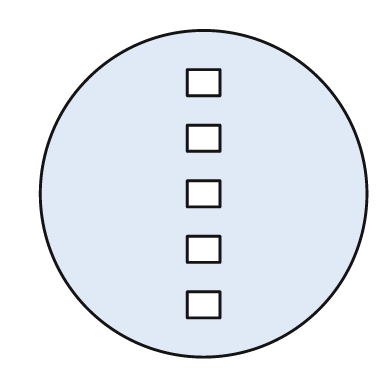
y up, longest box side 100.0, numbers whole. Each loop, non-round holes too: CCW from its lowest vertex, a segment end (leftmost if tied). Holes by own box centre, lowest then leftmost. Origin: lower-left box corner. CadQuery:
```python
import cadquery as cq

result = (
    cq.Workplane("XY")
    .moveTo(50.0, 50.0)
    .circle(50.0)
    .moveTo(45.0, 12.0)
    .lineTo(55.0, 12.0)
    .lineTo(55.0, 20.0)
    .lineTo(45.0, 20.0)
    .close()
    .moveTo(45.0, 29.0)
    .lineTo(55.0, 29.0)
    .lineTo(55.0, 37.0)
    .lineTo(45.0, 37.0)
    .close()
    .moveTo(45.0, 46.0)
    .lineTo(55.0, 46.0)
    .lineTo(55.0, 54.0)
    .lineTo(45.0, 54.0)
    .close()
    .moveTo(45.0, 63.0)
    .lineTo(55.0, 63.0)
    .lineTo(55.0, 71.0)
    .lineTo(45.0, 71.0)
    .close()
    .moveTo(45.0, 80.0)
    .lineTo(55.0, 80.0)
    .lineTo(55.0, 88.0)
    .lineTo(45.0, 88.0)
    .close()
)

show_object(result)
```